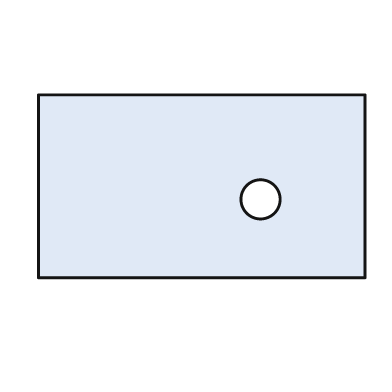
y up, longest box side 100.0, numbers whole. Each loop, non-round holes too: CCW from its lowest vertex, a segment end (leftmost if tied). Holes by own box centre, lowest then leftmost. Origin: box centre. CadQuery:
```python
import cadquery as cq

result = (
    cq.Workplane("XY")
    .moveTo(-50.0, -28.0)
    .lineTo(50.0, -28.0)
    .lineTo(50.0, 28.0)
    .lineTo(-50.0, 28.0)
    .close()
    .moveTo(18.0, -4.0)
    .circle(6.0)
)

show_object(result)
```